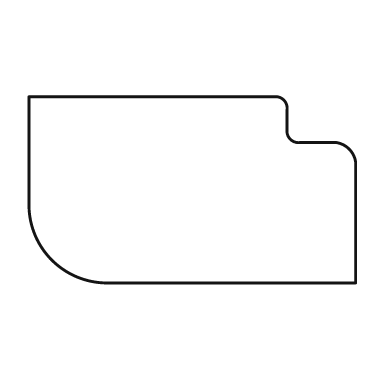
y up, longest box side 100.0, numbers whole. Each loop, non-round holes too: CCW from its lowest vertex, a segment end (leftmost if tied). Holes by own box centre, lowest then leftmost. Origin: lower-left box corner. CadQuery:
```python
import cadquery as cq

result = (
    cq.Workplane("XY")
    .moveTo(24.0, 0.0)
    .lineTo(100.0, 0.0)
    .lineTo(100.0, 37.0)
    .threePointArc((98.0, 41.0), (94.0, 43.0))
    .lineTo(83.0, 43.0)
    .threePointArc((80.0, 44.0), (79.0, 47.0))
    .lineTo(79.0, 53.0)
    .threePointArc((78.0, 56.0), (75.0, 57.0))
    .lineTo(0.0, 57.0)
    .lineTo(0.0, 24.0)
    .threePointArc((7.0, 7.0), (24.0, 0.0))
    .close()
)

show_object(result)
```